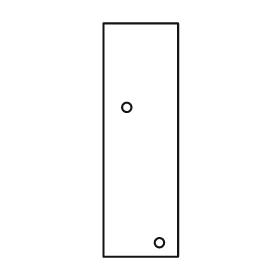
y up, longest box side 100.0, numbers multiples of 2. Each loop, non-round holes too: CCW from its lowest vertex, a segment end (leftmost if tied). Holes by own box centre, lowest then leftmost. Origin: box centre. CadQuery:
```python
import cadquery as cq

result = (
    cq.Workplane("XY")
    .moveTo(-16.0, -50.0)
    .lineTo(16.0, -50.0)
    .lineTo(16.0, 50.0)
    .lineTo(-16.0, 50.0)
    .close()
    .moveTo(8.0, -44.0)
    .circle(2.0)
    .moveTo(-6.0, 14.0)
    .circle(2.0)
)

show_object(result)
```